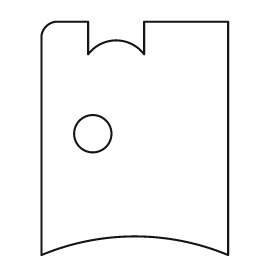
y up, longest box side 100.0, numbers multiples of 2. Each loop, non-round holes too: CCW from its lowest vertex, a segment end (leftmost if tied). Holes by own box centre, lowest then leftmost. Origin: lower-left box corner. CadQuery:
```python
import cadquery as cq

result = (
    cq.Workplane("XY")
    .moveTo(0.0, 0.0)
    .threePointArc((40.0, 8.0), (80.0, 0.0))
    .lineTo(80.0, 100.0)
    .lineTo(44.0, 100.0)
    .lineTo(44.0, 86.0)
    .threePointArc((32.0, 92.0), (20.0, 86.0))
    .lineTo(20.0, 100.0)
    .lineTo(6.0, 100.0)
    .threePointArc((2.0, 98.0), (0.0, 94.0))
    .close()
    .moveTo(22.0, 52.0)
    .circle(8.0)
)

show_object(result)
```